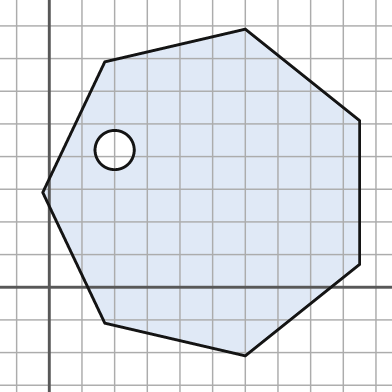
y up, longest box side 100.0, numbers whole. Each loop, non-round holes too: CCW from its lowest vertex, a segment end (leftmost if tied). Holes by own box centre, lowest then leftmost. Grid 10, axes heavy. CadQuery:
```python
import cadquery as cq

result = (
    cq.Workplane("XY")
    .moveTo(60.0, -21.0)
    .lineTo(95.0, 7.0)
    .lineTo(95.0, 51.0)
    .lineTo(60.0, 79.0)
    .lineTo(17.0, 69.0)
    .lineTo(-2.0, 29.0)
    .lineTo(17.0, -11.0)
    .close()
    .moveTo(20.0, 42.0)
    .circle(6.0)
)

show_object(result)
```